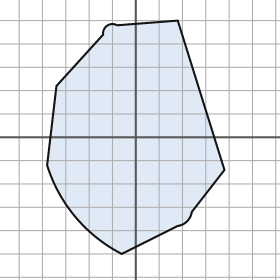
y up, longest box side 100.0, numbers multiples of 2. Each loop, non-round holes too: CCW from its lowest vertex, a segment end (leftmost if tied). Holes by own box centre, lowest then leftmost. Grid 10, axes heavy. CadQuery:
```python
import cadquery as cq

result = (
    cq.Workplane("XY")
    .moveTo(-6.0, -50.0)
    .lineTo(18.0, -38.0)
    .threePointArc((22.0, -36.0), (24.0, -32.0))
    .lineTo(38.0, -14.0)
    .lineTo(18.0, 50.0)
    .lineTo(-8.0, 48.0)
    .threePointArc((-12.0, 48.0), (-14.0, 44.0))
    .lineTo(-34.0, 22.0)
    .lineTo(-38.0, -12.0)
    .threePointArc((-26.0, -34.0), (-6.0, -50.0))
    .close()
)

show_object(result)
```